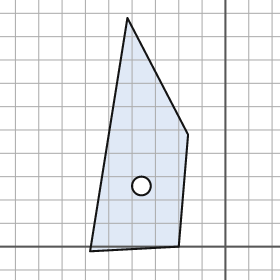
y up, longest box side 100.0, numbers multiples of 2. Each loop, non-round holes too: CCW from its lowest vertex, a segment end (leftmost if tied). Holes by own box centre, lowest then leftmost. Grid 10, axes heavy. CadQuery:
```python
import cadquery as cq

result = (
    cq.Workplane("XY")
    .moveTo(-58.0, -2.0)
    .lineTo(-20.0, 0.0)
    .lineTo(-16.0, 48.0)
    .lineTo(-42.0, 98.0)
    .close()
    .moveTo(-36.0, 26.0)
    .circle(4.0)
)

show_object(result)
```